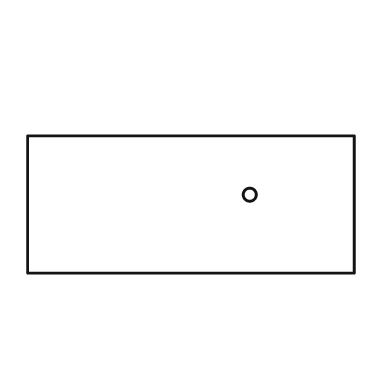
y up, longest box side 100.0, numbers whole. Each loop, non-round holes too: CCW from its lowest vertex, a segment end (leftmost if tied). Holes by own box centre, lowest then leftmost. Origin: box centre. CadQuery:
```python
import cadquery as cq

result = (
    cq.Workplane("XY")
    .moveTo(-50.0, -21.0)
    .lineTo(50.0, -21.0)
    .lineTo(50.0, 21.0)
    .lineTo(-50.0, 21.0)
    .close()
    .moveTo(18.0, 3.0)
    .circle(2.0)
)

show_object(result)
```